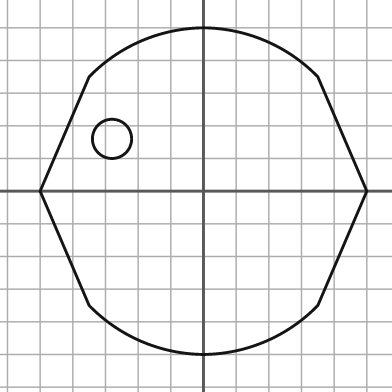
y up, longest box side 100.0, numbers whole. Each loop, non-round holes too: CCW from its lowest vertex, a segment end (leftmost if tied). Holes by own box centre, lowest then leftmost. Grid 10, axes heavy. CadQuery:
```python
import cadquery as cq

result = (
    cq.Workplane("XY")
    .moveTo(0.0, -50.0)
    .threePointArc((19.0, -46.0), (35.0, -35.0))
    .lineTo(50.0, 0.0)
    .lineTo(35.0, 35.0)
    .threePointArc((19.0, 46.0), (0.0, 50.0))
    .threePointArc((-19.0, 46.0), (-35.0, 35.0))
    .lineTo(-50.0, 0.0)
    .lineTo(-35.0, -35.0)
    .threePointArc((-19.0, -46.0), (0.0, -50.0))
    .close()
    .moveTo(-28.0, 16.0)
    .circle(6.0)
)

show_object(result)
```